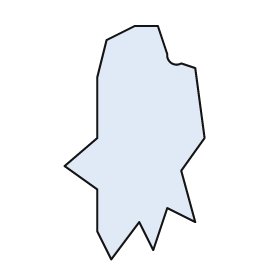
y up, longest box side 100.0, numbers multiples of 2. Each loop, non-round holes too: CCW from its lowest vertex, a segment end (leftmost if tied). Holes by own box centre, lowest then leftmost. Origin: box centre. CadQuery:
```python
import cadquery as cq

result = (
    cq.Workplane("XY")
    .moveTo(-10.0, -50.0)
    .lineTo(2.0, -34.0)
    .lineTo(8.0, -46.0)
    .lineTo(14.0, -28.0)
    .lineTo(26.0, -34.0)
    .lineTo(20.0, -12.0)
    .lineTo(30.0, 2.0)
    .lineTo(26.0, 32.0)
    .lineTo(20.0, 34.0)
    .threePointArc((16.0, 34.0), (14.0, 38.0))
    .lineTo(10.0, 50.0)
    .lineTo(0.0, 50.0)
    .lineTo(-12.0, 44.0)
    .lineTo(-16.0, 28.0)
    .lineTo(-16.0, 2.0)
    .lineTo(-30.0, -10.0)
    .lineTo(-16.0, -20.0)
    .lineTo(-16.0, -38.0)
    .close()
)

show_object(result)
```